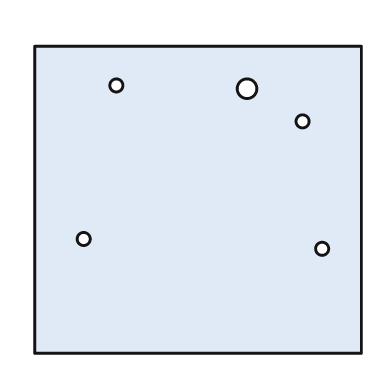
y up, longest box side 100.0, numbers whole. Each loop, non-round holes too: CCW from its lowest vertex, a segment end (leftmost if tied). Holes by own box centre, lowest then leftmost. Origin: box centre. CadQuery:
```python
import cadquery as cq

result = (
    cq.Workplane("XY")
    .moveTo(-50.0, -47.0)
    .lineTo(50.0, -47.0)
    .lineTo(50.0, 47.0)
    .lineTo(-50.0, 47.0)
    .close()
    .moveTo(38.0, -15.0)
    .circle(2.0)
    .moveTo(-35.0, -12.0)
    .circle(2.0)
    .moveTo(32.0, 24.0)
    .circle(2.0)
    .moveTo(15.0, 34.0)
    .circle(3.0)
    .moveTo(-25.0, 35.0)
    .circle(2.0)
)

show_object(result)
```